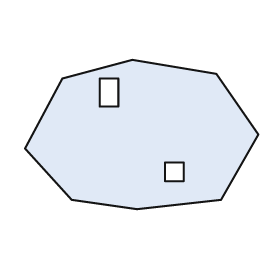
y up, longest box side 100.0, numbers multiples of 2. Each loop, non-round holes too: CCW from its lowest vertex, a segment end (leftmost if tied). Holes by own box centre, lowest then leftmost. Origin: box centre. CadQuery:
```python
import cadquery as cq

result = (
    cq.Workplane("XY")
    .moveTo(-2.0, -32.0)
    .lineTo(34.0, -28.0)
    .lineTo(50.0, 0.0)
    .lineTo(32.0, 26.0)
    .lineTo(-4.0, 32.0)
    .lineTo(-34.0, 24.0)
    .lineTo(-50.0, -6.0)
    .lineTo(-30.0, -28.0)
    .close()
    .moveTo(10.0, -20.0)
    .lineTo(18.0, -20.0)
    .lineTo(18.0, -12.0)
    .lineTo(10.0, -12.0)
    .close()
    .moveTo(-18.0, 12.0)
    .lineTo(-10.0, 12.0)
    .lineTo(-10.0, 24.0)
    .lineTo(-18.0, 24.0)
    .close()
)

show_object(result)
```